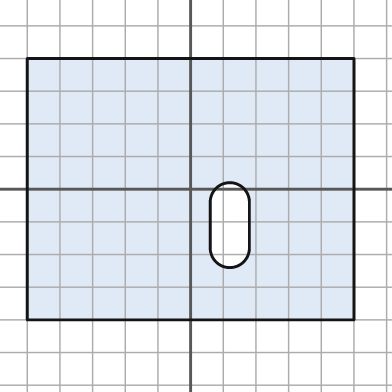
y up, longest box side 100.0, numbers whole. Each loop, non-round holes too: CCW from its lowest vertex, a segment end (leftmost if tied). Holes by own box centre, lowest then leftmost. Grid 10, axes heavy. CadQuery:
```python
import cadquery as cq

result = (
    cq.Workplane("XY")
    .moveTo(-50.0, -40.0)
    .lineTo(50.0, -40.0)
    .lineTo(50.0, 40.0)
    .lineTo(-50.0, 40.0)
    .close()
    .moveTo(6.0, -18.0)
    .threePointArc((12.0, -24.0), (18.0, -18.0))
    .lineTo(18.0, -4.0)
    .threePointArc((12.0, 2.0), (6.0, -4.0))
    .close()
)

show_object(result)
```